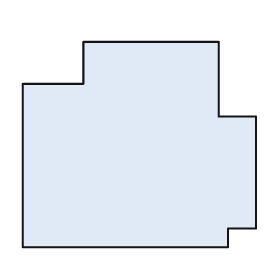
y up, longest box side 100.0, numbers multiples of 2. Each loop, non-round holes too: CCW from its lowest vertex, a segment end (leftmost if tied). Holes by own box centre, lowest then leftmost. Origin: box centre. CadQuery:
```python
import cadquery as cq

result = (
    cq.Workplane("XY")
    .moveTo(-50.0, -44.0)
    .lineTo(38.0, -44.0)
    .lineTo(38.0, -36.0)
    .lineTo(50.0, -36.0)
    .lineTo(50.0, 12.0)
    .lineTo(34.0, 12.0)
    .lineTo(34.0, 44.0)
    .lineTo(-24.0, 44.0)
    .lineTo(-24.0, 26.0)
    .lineTo(-50.0, 26.0)
    .close()
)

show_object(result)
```